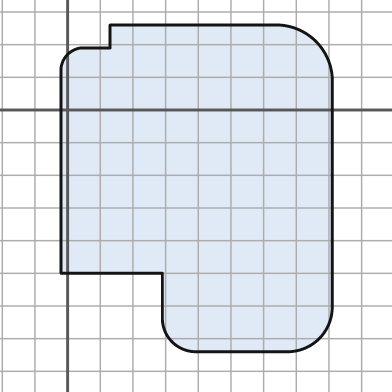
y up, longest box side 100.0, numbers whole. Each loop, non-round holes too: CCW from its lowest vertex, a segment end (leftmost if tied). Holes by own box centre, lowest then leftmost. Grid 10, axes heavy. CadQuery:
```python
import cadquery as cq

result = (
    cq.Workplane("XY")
    .moveTo(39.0, -74.0)
    .lineTo(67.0, -74.0)
    .threePointArc((77.0, -70.0), (81.0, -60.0))
    .lineTo(81.0, 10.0)
    .threePointArc((76.0, 21.0), (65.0, 26.0))
    .lineTo(13.0, 26.0)
    .lineTo(13.0, 19.0)
    .lineTo(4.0, 19.0)
    .threePointArc((0.0, 17.0), (-2.0, 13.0))
    .lineTo(-2.0, -50.0)
    .lineTo(29.0, -50.0)
    .lineTo(29.0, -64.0)
    .threePointArc((32.0, -71.0), (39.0, -74.0))
    .close()
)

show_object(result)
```